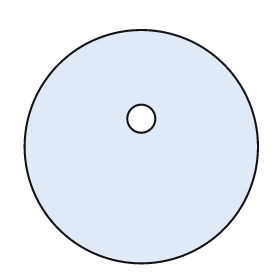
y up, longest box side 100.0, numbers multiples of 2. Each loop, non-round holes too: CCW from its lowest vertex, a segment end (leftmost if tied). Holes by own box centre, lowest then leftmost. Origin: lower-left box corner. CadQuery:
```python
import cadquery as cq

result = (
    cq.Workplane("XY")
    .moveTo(50.0, 50.0)
    .circle(50.0)
    .moveTo(50.0, 62.0)
    .circle(6.0)
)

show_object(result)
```